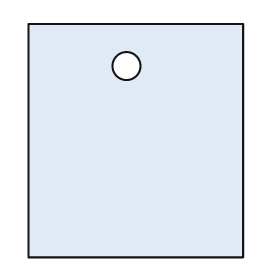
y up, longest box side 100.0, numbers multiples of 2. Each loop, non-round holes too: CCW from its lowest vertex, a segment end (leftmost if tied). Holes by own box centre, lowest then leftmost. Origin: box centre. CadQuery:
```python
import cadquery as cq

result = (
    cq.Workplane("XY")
    .moveTo(-46.0, -50.0)
    .lineTo(46.0, -50.0)
    .lineTo(46.0, 50.0)
    .lineTo(-46.0, 50.0)
    .close()
    .moveTo(-4.0, 32.0)
    .circle(6.0)
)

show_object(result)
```